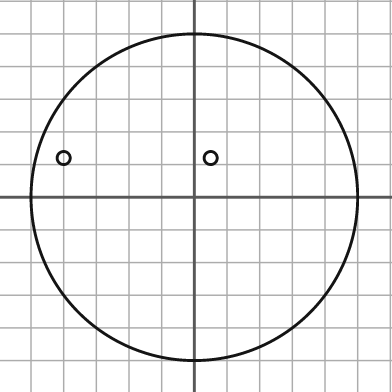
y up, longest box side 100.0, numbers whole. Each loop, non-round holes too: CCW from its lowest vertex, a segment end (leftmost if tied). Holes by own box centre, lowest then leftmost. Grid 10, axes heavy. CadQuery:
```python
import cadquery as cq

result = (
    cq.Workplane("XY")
    .moveTo(0.0, 0.0)
    .circle(50.0)
    .moveTo(-40.0, 12.0)
    .circle(2.0)
    .moveTo(5.0, 12.0)
    .circle(2.0)
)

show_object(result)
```